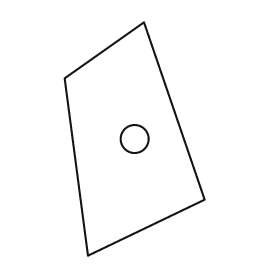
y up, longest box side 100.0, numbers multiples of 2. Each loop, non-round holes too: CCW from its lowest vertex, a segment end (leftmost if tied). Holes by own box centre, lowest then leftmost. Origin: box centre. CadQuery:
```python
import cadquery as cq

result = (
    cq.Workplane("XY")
    .moveTo(-20.0, -50.0)
    .lineTo(30.0, -26.0)
    .lineTo(4.0, 50.0)
    .lineTo(-30.0, 26.0)
    .close()
    .moveTo(0.0, 0.0)
    .circle(6.0)
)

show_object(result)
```